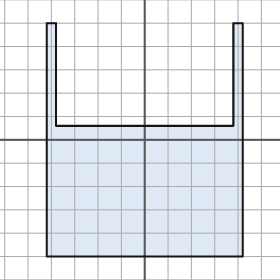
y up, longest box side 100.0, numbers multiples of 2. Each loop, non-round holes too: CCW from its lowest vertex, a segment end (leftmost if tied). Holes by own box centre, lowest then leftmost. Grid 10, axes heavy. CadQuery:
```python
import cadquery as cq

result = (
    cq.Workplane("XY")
    .moveTo(-42.0, -50.0)
    .lineTo(42.0, -50.0)
    .lineTo(42.0, 50.0)
    .lineTo(38.0, 50.0)
    .lineTo(38.0, 6.0)
    .lineTo(-38.0, 6.0)
    .lineTo(-38.0, 50.0)
    .lineTo(-42.0, 50.0)
    .close()
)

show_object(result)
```